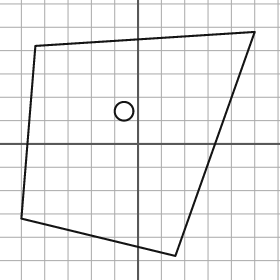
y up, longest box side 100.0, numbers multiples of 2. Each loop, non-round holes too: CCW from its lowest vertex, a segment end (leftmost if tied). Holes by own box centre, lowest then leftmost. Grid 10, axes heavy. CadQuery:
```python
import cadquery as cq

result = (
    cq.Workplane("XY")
    .moveTo(16.0, -48.0)
    .lineTo(50.0, 48.0)
    .lineTo(-44.0, 42.0)
    .lineTo(-50.0, -32.0)
    .close()
    .moveTo(-6.0, 14.0)
    .circle(4.0)
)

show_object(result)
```